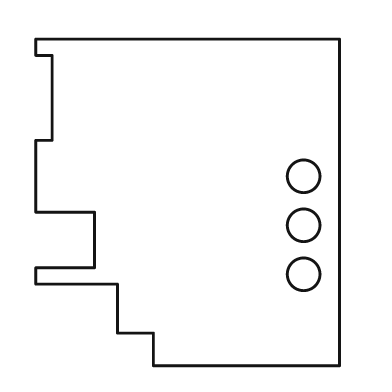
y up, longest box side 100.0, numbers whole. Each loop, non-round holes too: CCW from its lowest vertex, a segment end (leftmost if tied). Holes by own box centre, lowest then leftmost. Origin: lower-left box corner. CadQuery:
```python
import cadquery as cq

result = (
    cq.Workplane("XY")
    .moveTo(36.0, 0.0)
    .lineTo(93.0, 0.0)
    .lineTo(93.0, 100.0)
    .lineTo(0.0, 100.0)
    .lineTo(0.0, 95.0)
    .lineTo(5.0, 95.0)
    .lineTo(5.0, 69.0)
    .lineTo(0.0, 69.0)
    .lineTo(0.0, 47.0)
    .lineTo(18.0, 47.0)
    .lineTo(18.0, 30.0)
    .lineTo(0.0, 30.0)
    .lineTo(0.0, 25.0)
    .lineTo(25.0, 25.0)
    .lineTo(25.0, 10.0)
    .lineTo(36.0, 10.0)
    .close()
    .moveTo(82.0, 28.0)
    .circle(5.0)
    .moveTo(82.0, 43.0)
    .circle(5.0)
    .moveTo(82.0, 58.0)
    .circle(5.0)
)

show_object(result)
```